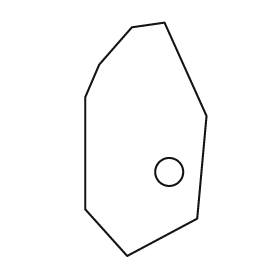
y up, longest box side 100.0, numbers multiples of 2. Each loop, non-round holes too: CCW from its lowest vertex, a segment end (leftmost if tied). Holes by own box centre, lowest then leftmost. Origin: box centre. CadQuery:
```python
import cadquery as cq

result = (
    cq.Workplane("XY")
    .moveTo(-8.0, -50.0)
    .lineTo(22.0, -34.0)
    .lineTo(26.0, 10.0)
    .lineTo(8.0, 50.0)
    .lineTo(-6.0, 48.0)
    .lineTo(-20.0, 32.0)
    .lineTo(-26.0, 18.0)
    .lineTo(-26.0, -30.0)
    .close()
    .moveTo(10.0, -14.0)
    .circle(6.0)
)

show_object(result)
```